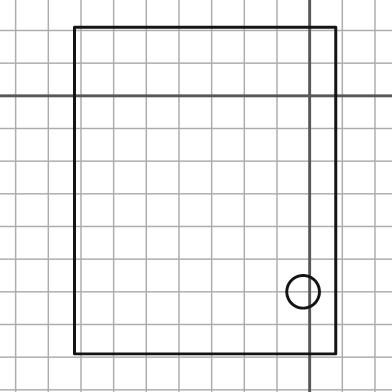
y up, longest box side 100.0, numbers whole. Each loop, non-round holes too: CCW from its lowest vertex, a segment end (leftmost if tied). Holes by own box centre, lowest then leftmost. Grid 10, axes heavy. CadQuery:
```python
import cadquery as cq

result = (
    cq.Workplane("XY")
    .moveTo(-72.0, -79.0)
    .lineTo(8.0, -79.0)
    .lineTo(8.0, 21.0)
    .lineTo(-72.0, 21.0)
    .close()
    .moveTo(-2.0, -60.0)
    .circle(5.0)
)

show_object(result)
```